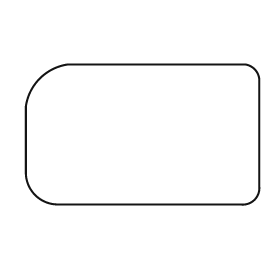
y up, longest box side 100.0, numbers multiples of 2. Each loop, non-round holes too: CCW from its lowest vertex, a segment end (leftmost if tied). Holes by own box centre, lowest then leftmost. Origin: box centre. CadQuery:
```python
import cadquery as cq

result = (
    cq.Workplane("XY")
    .moveTo(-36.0, -30.0)
    .lineTo(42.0, -30.0)
    .threePointArc((48.0, -28.0), (50.0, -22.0))
    .lineTo(50.0, 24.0)
    .threePointArc((48.0, 28.0), (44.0, 30.0))
    .lineTo(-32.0, 30.0)
    .threePointArc((-44.0, 24.0), (-50.0, 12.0))
    .lineTo(-50.0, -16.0)
    .threePointArc((-46.0, -26.0), (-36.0, -30.0))
    .close()
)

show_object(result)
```